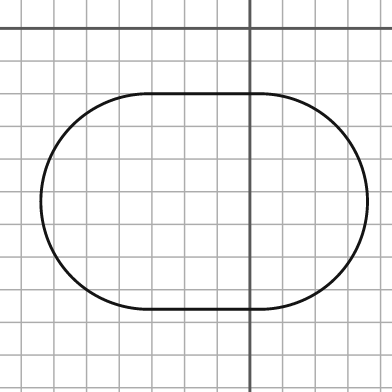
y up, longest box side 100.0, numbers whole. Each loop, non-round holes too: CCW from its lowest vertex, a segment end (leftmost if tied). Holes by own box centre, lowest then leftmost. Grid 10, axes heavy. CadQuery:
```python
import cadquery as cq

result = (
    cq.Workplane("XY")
    .moveTo(-31.0, -86.0)
    .lineTo(3.0, -86.0)
    .threePointArc((36.0, -53.0), (3.0, -20.0))
    .lineTo(-31.0, -20.0)
    .threePointArc((-64.0, -53.0), (-31.0, -86.0))
    .close()
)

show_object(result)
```